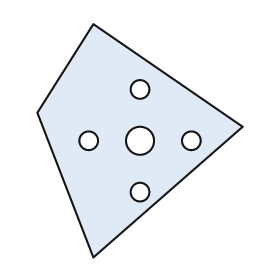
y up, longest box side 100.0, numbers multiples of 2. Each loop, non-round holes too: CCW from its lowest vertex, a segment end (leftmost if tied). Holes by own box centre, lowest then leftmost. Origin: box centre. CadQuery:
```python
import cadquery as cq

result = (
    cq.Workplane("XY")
    .moveTo(-20.0, -50.0)
    .lineTo(44.0, 6.0)
    .lineTo(-20.0, 50.0)
    .lineTo(-44.0, 12.0)
    .close()
    .moveTo(0.0, -22.0)
    .circle(4.0)
    .moveTo(-22.0, 0.0)
    .circle(4.0)
    .moveTo(0.0, 0.0)
    .circle(6.0)
    .moveTo(22.0, 0.0)
    .circle(4.0)
    .moveTo(0.0, 22.0)
    .circle(4.0)
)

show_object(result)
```